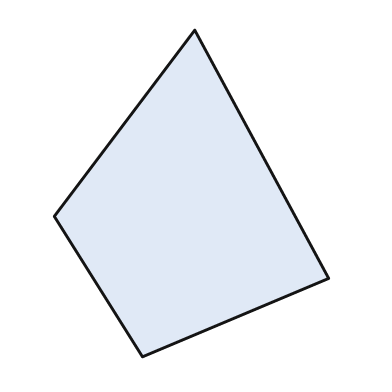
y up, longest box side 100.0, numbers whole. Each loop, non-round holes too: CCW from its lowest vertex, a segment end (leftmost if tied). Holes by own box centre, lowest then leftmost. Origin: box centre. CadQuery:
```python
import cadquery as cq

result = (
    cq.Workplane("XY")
    .moveTo(-15.0, -50.0)
    .lineTo(42.0, -26.0)
    .lineTo(1.0, 50.0)
    .lineTo(-42.0, -7.0)
    .close()
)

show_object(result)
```